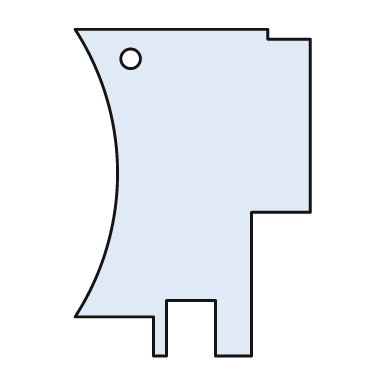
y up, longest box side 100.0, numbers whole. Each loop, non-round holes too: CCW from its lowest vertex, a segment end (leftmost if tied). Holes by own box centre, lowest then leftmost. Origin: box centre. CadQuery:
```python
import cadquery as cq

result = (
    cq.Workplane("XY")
    .moveTo(-12.0, -50.0)
    .lineTo(-8.0, -50.0)
    .lineTo(-8.0, -33.0)
    .lineTo(7.0, -33.0)
    .lineTo(7.0, -50.0)
    .lineTo(18.0, -50.0)
    .lineTo(18.0, -6.0)
    .lineTo(36.0, -6.0)
    .lineTo(36.0, 47.0)
    .lineTo(23.0, 47.0)
    .lineTo(23.0, 50.0)
    .lineTo(-36.0, 50.0)
    .threePointArc((-23.0, 6.0), (-36.0, -38.0))
    .lineTo(-12.0, -38.0)
    .close()
    .moveTo(-19.0, 41.0)
    .circle(3.0)
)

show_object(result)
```